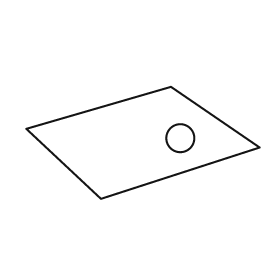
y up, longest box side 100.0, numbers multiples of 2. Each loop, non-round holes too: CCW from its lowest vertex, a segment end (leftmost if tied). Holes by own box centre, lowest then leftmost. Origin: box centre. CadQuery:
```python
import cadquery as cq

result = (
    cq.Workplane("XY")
    .moveTo(-18.0, -24.0)
    .lineTo(50.0, -2.0)
    .lineTo(12.0, 24.0)
    .lineTo(-50.0, 6.0)
    .close()
    .moveTo(16.0, 2.0)
    .circle(6.0)
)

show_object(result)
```